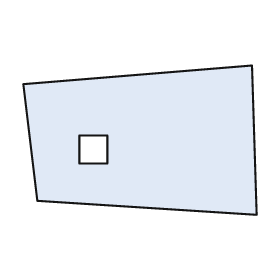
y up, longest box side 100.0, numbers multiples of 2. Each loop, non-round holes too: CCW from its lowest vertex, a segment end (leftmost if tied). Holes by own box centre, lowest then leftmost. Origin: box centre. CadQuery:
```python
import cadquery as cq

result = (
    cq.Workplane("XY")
    .moveTo(50.0, -32.0)
    .lineTo(48.0, 32.0)
    .lineTo(-50.0, 24.0)
    .lineTo(-44.0, -26.0)
    .close()
    .moveTo(-26.0, -10.0)
    .lineTo(-14.0, -10.0)
    .lineTo(-14.0, 2.0)
    .lineTo(-26.0, 2.0)
    .close()
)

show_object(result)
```